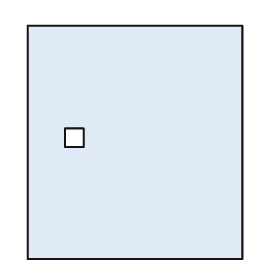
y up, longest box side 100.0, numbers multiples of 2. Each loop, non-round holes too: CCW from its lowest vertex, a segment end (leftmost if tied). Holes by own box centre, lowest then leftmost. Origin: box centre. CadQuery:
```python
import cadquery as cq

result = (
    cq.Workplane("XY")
    .moveTo(-46.0, -50.0)
    .lineTo(46.0, -50.0)
    .lineTo(46.0, 50.0)
    .lineTo(-46.0, 50.0)
    .close()
    .moveTo(-30.0, -2.0)
    .lineTo(-22.0, -2.0)
    .lineTo(-22.0, 6.0)
    .lineTo(-30.0, 6.0)
    .close()
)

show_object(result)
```